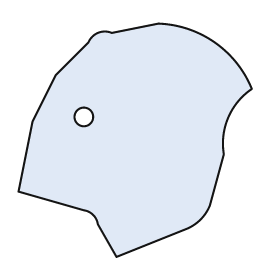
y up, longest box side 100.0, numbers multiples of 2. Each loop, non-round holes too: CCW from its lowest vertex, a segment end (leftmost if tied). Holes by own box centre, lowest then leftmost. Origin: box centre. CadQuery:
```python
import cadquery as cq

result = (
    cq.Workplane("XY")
    .moveTo(-8.0, -50.0)
    .lineTo(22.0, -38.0)
    .threePointArc((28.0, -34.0), (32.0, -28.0))
    .lineTo(38.0, -6.0)
    .threePointArc((40.0, 10.0), (50.0, 22.0))
    .threePointArc((34.0, 42.0), (10.0, 50.0))
    .lineTo(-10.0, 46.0)
    .threePointArc((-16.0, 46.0), (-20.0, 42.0))
    .lineTo(-34.0, 28.0)
    .lineTo(-44.0, 8.0)
    .lineTo(-50.0, -22.0)
    .lineTo(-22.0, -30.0)
    .threePointArc((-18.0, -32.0), (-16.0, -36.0))
    .close()
    .moveTo(-22.0, 10.0)
    .circle(4.0)
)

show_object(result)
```